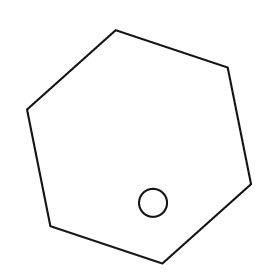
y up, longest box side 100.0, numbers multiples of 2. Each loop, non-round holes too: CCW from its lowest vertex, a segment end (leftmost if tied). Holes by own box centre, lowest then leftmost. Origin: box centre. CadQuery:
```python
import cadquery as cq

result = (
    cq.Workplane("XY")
    .moveTo(10.0, -50.0)
    .lineTo(48.0, -16.0)
    .lineTo(38.0, 34.0)
    .lineTo(-10.0, 50.0)
    .lineTo(-48.0, 16.0)
    .lineTo(-38.0, -34.0)
    .close()
    .moveTo(6.0, -24.0)
    .circle(6.0)
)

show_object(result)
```